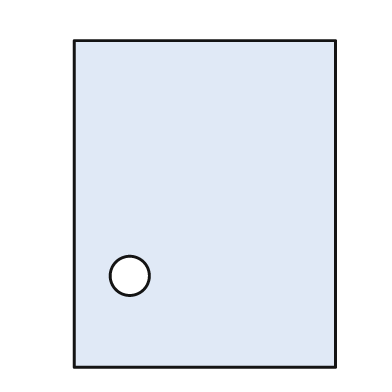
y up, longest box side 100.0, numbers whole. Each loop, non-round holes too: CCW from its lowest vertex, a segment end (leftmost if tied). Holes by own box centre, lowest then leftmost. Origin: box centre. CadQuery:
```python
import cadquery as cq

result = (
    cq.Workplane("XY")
    .moveTo(-40.0, -50.0)
    .lineTo(40.0, -50.0)
    .lineTo(40.0, 50.0)
    .lineTo(-40.0, 50.0)
    .close()
    .moveTo(-23.0, -22.0)
    .circle(6.0)
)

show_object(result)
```